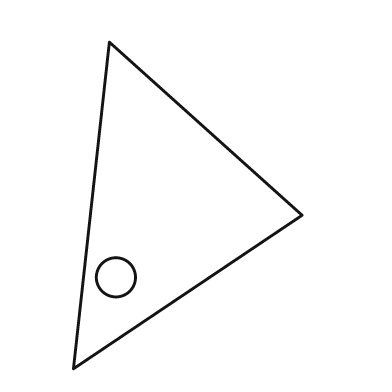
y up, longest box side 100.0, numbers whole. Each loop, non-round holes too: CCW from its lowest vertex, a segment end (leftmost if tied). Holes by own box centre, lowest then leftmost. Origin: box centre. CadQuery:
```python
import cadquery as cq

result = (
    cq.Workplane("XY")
    .moveTo(-35.0, -50.0)
    .lineTo(35.0, -3.0)
    .lineTo(-24.0, 50.0)
    .close()
    .moveTo(-22.0, -22.0)
    .circle(6.0)
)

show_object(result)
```